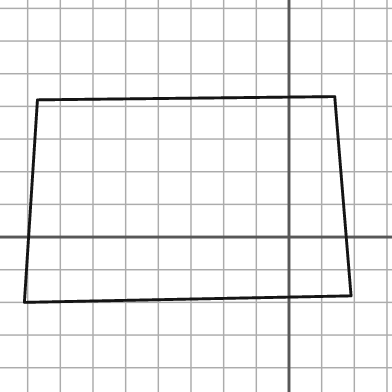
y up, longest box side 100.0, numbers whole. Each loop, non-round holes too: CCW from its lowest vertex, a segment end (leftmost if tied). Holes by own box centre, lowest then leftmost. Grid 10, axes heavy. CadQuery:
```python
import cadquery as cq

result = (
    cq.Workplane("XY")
    .moveTo(-81.0, -20.0)
    .lineTo(19.0, -18.0)
    .lineTo(14.0, 43.0)
    .lineTo(-77.0, 42.0)
    .close()
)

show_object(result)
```